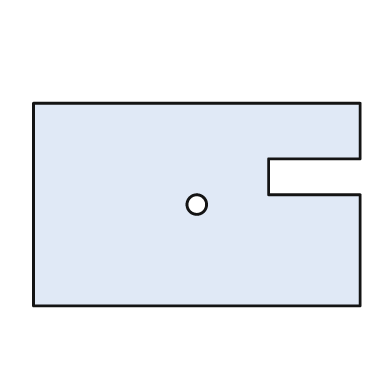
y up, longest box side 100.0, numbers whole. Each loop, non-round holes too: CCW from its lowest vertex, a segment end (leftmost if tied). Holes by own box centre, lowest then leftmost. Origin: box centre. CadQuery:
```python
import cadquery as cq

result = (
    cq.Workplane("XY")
    .moveTo(-50.0, -31.0)
    .lineTo(50.0, -31.0)
    .lineTo(50.0, 3.0)
    .lineTo(22.0, 3.0)
    .lineTo(22.0, 14.0)
    .lineTo(50.0, 14.0)
    .lineTo(50.0, 31.0)
    .lineTo(-50.0, 31.0)
    .close()
    .moveTo(0.0, 0.0)
    .circle(3.0)
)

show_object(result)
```